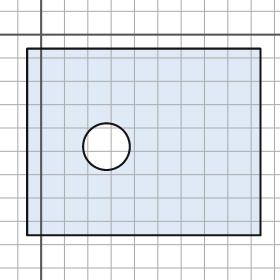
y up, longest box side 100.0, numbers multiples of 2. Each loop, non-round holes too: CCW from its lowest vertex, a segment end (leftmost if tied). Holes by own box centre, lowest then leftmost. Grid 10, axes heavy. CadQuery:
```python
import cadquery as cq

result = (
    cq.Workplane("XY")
    .moveTo(-6.0, -86.0)
    .lineTo(94.0, -86.0)
    .lineTo(94.0, -6.0)
    .lineTo(-6.0, -6.0)
    .close()
    .moveTo(28.0, -48.0)
    .circle(10.0)
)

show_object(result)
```